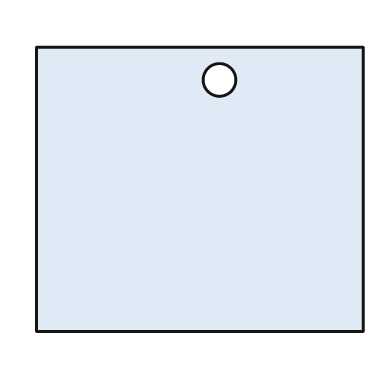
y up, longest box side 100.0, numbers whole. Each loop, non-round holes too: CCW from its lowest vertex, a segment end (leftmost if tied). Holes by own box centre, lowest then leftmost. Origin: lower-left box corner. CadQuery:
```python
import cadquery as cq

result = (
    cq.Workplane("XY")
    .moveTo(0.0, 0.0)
    .lineTo(100.0, 0.0)
    .lineTo(100.0, 87.0)
    .lineTo(0.0, 87.0)
    .close()
    .moveTo(56.0, 77.0)
    .circle(5.0)
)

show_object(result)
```